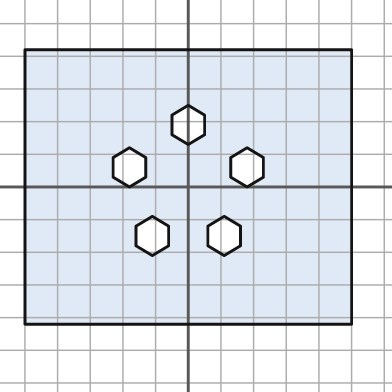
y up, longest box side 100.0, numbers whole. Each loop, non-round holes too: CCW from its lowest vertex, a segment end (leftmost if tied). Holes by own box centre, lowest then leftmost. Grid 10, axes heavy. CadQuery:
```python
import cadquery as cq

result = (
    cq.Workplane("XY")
    .moveTo(-50.0, -42.0)
    .lineTo(50.0, -42.0)
    .lineTo(50.0, 42.0)
    .lineTo(-50.0, 42.0)
    .close()
    .moveTo(-11.0, -21.0)
    .lineTo(-6.0, -18.0)
    .lineTo(-6.0, -12.0)
    .lineTo(-11.0, -9.0)
    .lineTo(-16.0, -12.0)
    .lineTo(-16.0, -18.0)
    .close()
    .moveTo(11.0, -21.0)
    .lineTo(16.0, -18.0)
    .lineTo(16.0, -12.0)
    .lineTo(11.0, -9.0)
    .lineTo(6.0, -12.0)
    .lineTo(6.0, -18.0)
    .close()
    .moveTo(-18.0, 0.0)
    .lineTo(-13.0, 3.0)
    .lineTo(-13.0, 9.0)
    .lineTo(-18.0, 12.0)
    .lineTo(-23.0, 9.0)
    .lineTo(-23.0, 3.0)
    .close()
    .moveTo(18.0, 0.0)
    .lineTo(23.0, 3.0)
    .lineTo(23.0, 9.0)
    .lineTo(18.0, 12.0)
    .lineTo(13.0, 9.0)
    .lineTo(13.0, 3.0)
    .close()
    .moveTo(0.0, 13.0)
    .lineTo(5.0, 16.0)
    .lineTo(5.0, 22.0)
    .lineTo(0.0, 25.0)
    .lineTo(-5.0, 22.0)
    .lineTo(-5.0, 16.0)
    .close()
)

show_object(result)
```